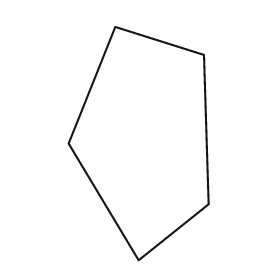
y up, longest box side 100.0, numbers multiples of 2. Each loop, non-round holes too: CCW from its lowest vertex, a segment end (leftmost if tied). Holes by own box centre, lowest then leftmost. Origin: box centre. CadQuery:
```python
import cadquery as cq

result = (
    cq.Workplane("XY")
    .moveTo(0.0, -50.0)
    .lineTo(30.0, -26.0)
    .lineTo(28.0, 38.0)
    .lineTo(-10.0, 50.0)
    .lineTo(-30.0, 0.0)
    .close()
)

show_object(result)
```